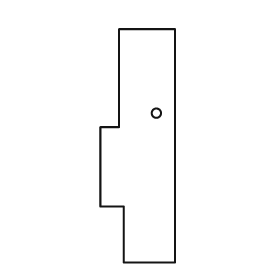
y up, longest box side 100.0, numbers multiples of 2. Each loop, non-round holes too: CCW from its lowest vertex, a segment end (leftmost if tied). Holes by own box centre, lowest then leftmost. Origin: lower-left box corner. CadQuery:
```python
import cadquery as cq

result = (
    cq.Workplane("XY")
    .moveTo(10.0, 0.0)
    .lineTo(32.0, 0.0)
    .lineTo(32.0, 100.0)
    .lineTo(8.0, 100.0)
    .lineTo(8.0, 58.0)
    .lineTo(0.0, 58.0)
    .lineTo(0.0, 24.0)
    .lineTo(10.0, 24.0)
    .close()
    .moveTo(24.0, 64.0)
    .circle(2.0)
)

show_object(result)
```